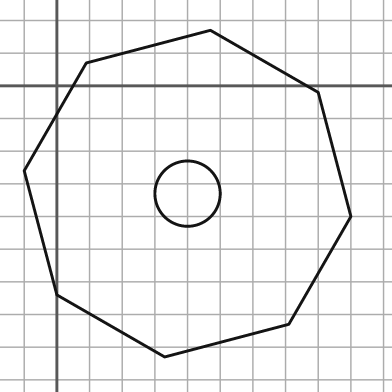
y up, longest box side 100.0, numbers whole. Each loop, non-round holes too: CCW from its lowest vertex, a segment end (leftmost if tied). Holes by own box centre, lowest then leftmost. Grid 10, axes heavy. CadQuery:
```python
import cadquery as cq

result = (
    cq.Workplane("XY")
    .moveTo(33.0, -83.0)
    .lineTo(71.0, -73.0)
    .lineTo(90.0, -40.0)
    .lineTo(80.0, -2.0)
    .lineTo(47.0, 17.0)
    .lineTo(9.0, 7.0)
    .lineTo(-10.0, -26.0)
    .lineTo(0.0, -64.0)
    .close()
    .moveTo(40.0, -33.0)
    .circle(10.0)
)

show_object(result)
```